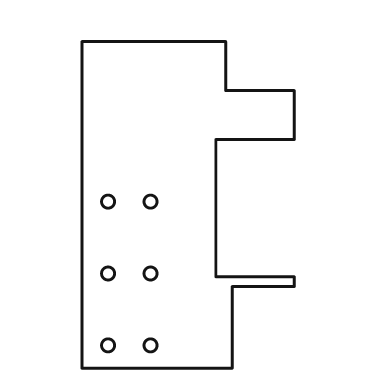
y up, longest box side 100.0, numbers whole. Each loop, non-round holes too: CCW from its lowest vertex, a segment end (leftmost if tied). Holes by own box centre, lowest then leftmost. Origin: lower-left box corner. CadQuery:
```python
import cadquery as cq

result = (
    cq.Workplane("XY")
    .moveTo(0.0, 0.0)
    .lineTo(46.0, 0.0)
    .lineTo(46.0, 25.0)
    .lineTo(65.0, 25.0)
    .lineTo(65.0, 28.0)
    .lineTo(41.0, 28.0)
    .lineTo(41.0, 70.0)
    .lineTo(65.0, 70.0)
    .lineTo(65.0, 85.0)
    .lineTo(44.0, 85.0)
    .lineTo(44.0, 100.0)
    .lineTo(0.0, 100.0)
    .close()
    .moveTo(8.0, 7.0)
    .circle(2.0)
    .moveTo(21.0, 7.0)
    .circle(2.0)
    .moveTo(8.0, 29.0)
    .circle(2.0)
    .moveTo(21.0, 29.0)
    .circle(2.0)
    .moveTo(8.0, 51.0)
    .circle(2.0)
    .moveTo(21.0, 51.0)
    .circle(2.0)
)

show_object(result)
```